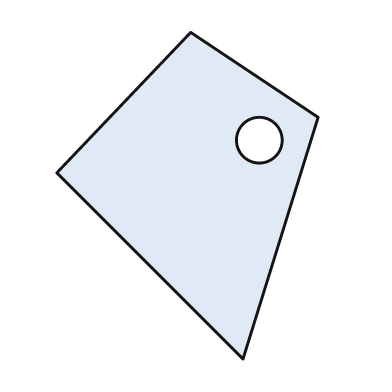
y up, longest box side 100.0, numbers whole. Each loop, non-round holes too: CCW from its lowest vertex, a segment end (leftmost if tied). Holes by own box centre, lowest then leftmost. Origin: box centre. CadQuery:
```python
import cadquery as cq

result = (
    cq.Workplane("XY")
    .moveTo(17.0, -50.0)
    .lineTo(40.0, 24.0)
    .lineTo(1.0, 50.0)
    .lineTo(-40.0, 7.0)
    .close()
    .moveTo(22.0, 17.0)
    .circle(7.0)
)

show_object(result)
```